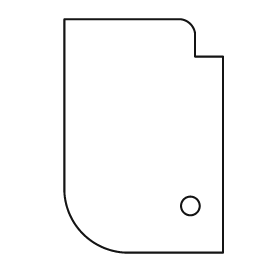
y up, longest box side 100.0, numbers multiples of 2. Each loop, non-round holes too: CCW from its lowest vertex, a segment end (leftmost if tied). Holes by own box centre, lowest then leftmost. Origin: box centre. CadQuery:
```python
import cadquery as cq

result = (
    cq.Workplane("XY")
    .moveTo(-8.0, -50.0)
    .lineTo(34.0, -50.0)
    .lineTo(34.0, 34.0)
    .lineTo(22.0, 34.0)
    .lineTo(22.0, 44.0)
    .threePointArc((20.0, 48.0), (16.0, 50.0))
    .lineTo(-34.0, 50.0)
    .lineTo(-34.0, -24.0)
    .threePointArc((-26.0, -42.0), (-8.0, -50.0))
    .close()
    .moveTo(20.0, -30.0)
    .circle(4.0)
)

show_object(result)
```